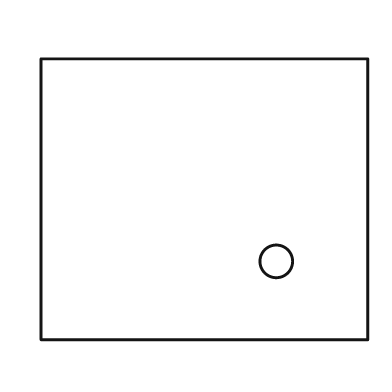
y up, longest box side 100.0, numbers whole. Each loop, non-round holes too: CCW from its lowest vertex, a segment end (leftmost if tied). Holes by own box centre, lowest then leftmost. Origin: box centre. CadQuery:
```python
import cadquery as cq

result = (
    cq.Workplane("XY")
    .moveTo(-50.0, -43.0)
    .lineTo(50.0, -43.0)
    .lineTo(50.0, 43.0)
    .lineTo(-50.0, 43.0)
    .close()
    .moveTo(22.0, -19.0)
    .circle(5.0)
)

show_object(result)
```